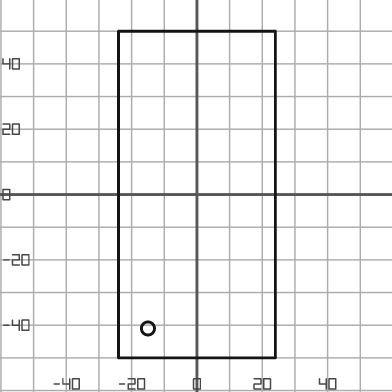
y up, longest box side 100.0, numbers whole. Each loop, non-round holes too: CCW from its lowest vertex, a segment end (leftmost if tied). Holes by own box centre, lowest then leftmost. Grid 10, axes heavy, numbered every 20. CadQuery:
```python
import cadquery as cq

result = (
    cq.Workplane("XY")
    .moveTo(-24.0, -50.0)
    .lineTo(24.0, -50.0)
    .lineTo(24.0, 50.0)
    .lineTo(-24.0, 50.0)
    .close()
    .moveTo(-15.0, -41.0)
    .circle(2.0)
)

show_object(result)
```